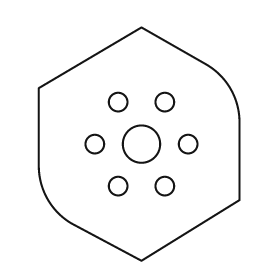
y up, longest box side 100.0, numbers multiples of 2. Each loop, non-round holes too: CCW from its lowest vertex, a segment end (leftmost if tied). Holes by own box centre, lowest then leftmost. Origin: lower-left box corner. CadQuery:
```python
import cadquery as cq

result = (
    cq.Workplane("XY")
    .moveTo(44.0, 0.0)
    .lineTo(86.0, 26.0)
    .lineTo(86.0, 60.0)
    .threePointArc((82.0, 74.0), (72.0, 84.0))
    .lineTo(44.0, 100.0)
    .lineTo(0.0, 74.0)
    .lineTo(0.0, 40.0)
    .threePointArc((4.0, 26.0), (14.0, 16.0))
    .close()
    .moveTo(34.0, 32.0)
    .circle(4.0)
    .moveTo(54.0, 32.0)
    .circle(4.0)
    .moveTo(24.0, 50.0)
    .circle(4.0)
    .moveTo(44.0, 50.0)
    .circle(8.0)
    .moveTo(64.0, 50.0)
    .circle(4.0)
    .moveTo(34.0, 68.0)
    .circle(4.0)
    .moveTo(54.0, 68.0)
    .circle(4.0)
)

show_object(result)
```